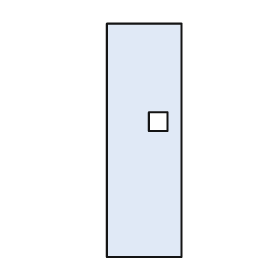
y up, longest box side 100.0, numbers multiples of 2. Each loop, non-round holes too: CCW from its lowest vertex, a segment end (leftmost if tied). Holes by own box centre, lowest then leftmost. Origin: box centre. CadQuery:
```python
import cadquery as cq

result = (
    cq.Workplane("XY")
    .moveTo(-16.0, -50.0)
    .lineTo(16.0, -50.0)
    .lineTo(16.0, 50.0)
    .lineTo(-16.0, 50.0)
    .close()
    .moveTo(2.0, 4.0)
    .lineTo(10.0, 4.0)
    .lineTo(10.0, 12.0)
    .lineTo(2.0, 12.0)
    .close()
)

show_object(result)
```